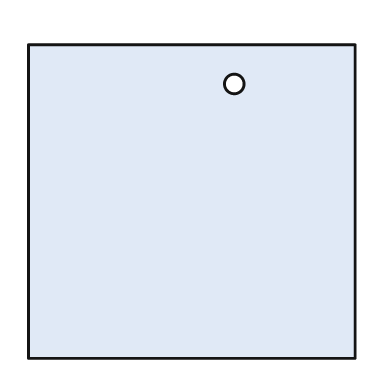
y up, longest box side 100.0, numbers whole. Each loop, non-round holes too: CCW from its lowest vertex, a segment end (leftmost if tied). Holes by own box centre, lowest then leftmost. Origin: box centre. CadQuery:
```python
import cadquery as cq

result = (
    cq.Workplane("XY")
    .moveTo(-50.0, -48.0)
    .lineTo(50.0, -48.0)
    .lineTo(50.0, 48.0)
    .lineTo(-50.0, 48.0)
    .close()
    .moveTo(13.0, 36.0)
    .circle(3.0)
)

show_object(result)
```